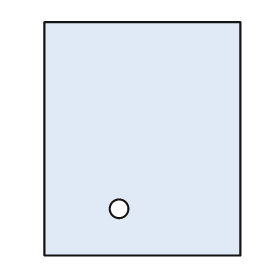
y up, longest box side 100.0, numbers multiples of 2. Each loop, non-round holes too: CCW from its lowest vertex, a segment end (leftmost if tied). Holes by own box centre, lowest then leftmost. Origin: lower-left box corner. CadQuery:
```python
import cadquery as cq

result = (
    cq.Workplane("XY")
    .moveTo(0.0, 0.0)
    .lineTo(84.0, 0.0)
    .lineTo(84.0, 100.0)
    .lineTo(0.0, 100.0)
    .close()
    .moveTo(32.0, 20.0)
    .circle(4.0)
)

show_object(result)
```